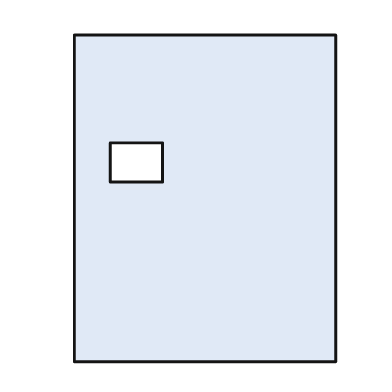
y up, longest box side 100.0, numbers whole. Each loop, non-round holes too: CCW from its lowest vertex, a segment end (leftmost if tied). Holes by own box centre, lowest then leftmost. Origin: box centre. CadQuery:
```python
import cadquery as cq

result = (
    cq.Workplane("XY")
    .moveTo(-40.0, -50.0)
    .lineTo(40.0, -50.0)
    .lineTo(40.0, 50.0)
    .lineTo(-40.0, 50.0)
    .close()
    .moveTo(-29.0, 5.0)
    .lineTo(-13.0, 5.0)
    .lineTo(-13.0, 17.0)
    .lineTo(-29.0, 17.0)
    .close()
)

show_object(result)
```